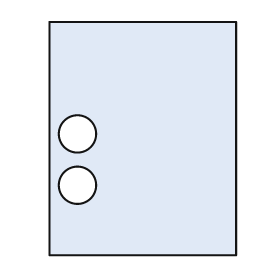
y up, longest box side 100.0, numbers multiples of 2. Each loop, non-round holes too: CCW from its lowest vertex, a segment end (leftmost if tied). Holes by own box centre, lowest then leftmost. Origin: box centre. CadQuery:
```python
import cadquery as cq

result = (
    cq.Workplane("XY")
    .moveTo(-40.0, -50.0)
    .lineTo(40.0, -50.0)
    .lineTo(40.0, 50.0)
    .lineTo(-40.0, 50.0)
    .close()
    .moveTo(-28.0, -20.0)
    .circle(8.0)
    .moveTo(-28.0, 2.0)
    .circle(8.0)
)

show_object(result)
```